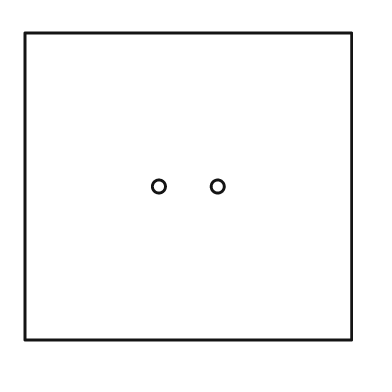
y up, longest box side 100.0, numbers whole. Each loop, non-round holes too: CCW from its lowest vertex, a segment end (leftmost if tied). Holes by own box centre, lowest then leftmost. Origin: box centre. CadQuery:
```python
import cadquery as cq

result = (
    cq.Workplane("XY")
    .moveTo(-50.0, -47.0)
    .lineTo(50.0, -47.0)
    .lineTo(50.0, 47.0)
    .lineTo(-50.0, 47.0)
    .close()
    .moveTo(-9.0, 0.0)
    .circle(2.0)
    .moveTo(9.0, 0.0)
    .circle(2.0)
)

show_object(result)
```